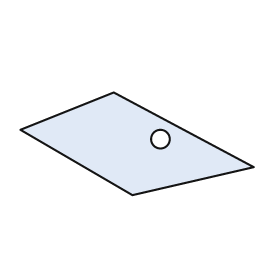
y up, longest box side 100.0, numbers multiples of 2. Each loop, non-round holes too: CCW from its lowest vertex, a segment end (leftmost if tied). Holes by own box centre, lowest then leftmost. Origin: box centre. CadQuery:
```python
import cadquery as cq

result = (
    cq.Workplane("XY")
    .moveTo(-2.0, -22.0)
    .lineTo(50.0, -10.0)
    .lineTo(-10.0, 22.0)
    .lineTo(-50.0, 6.0)
    .close()
    .moveTo(10.0, 2.0)
    .circle(4.0)
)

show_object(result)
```